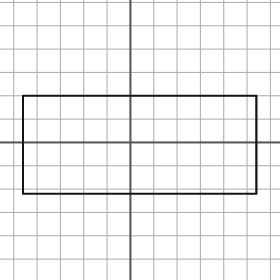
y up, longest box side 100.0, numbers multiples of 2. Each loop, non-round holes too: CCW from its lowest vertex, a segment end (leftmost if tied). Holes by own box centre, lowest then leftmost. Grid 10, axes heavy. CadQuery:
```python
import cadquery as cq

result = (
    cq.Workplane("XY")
    .moveTo(-46.0, -22.0)
    .lineTo(54.0, -22.0)
    .lineTo(54.0, 20.0)
    .lineTo(-46.0, 20.0)
    .close()
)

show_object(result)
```